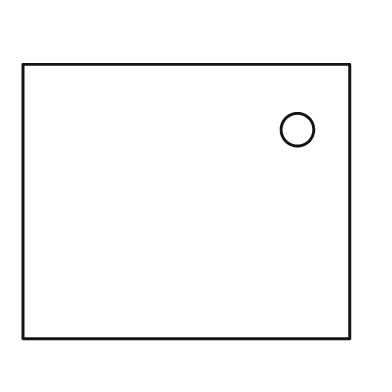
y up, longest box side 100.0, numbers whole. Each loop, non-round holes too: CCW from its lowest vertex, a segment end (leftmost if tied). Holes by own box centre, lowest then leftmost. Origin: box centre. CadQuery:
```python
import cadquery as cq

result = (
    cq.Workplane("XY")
    .moveTo(-50.0, -42.0)
    .lineTo(50.0, -42.0)
    .lineTo(50.0, 42.0)
    .lineTo(-50.0, 42.0)
    .close()
    .moveTo(34.0, 22.0)
    .circle(5.0)
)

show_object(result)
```